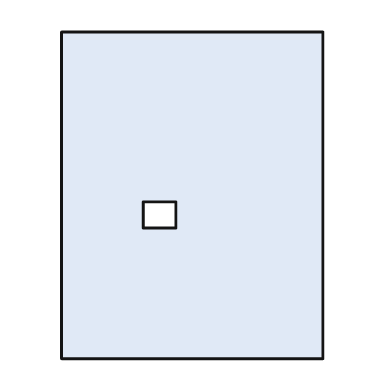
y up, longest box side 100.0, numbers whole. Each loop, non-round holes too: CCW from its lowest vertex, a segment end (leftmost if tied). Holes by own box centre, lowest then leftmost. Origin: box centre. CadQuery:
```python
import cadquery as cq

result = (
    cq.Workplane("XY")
    .moveTo(-40.0, -50.0)
    .lineTo(40.0, -50.0)
    .lineTo(40.0, 50.0)
    .lineTo(-40.0, 50.0)
    .close()
    .moveTo(-15.0, -10.0)
    .lineTo(-5.0, -10.0)
    .lineTo(-5.0, -2.0)
    .lineTo(-15.0, -2.0)
    .close()
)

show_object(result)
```